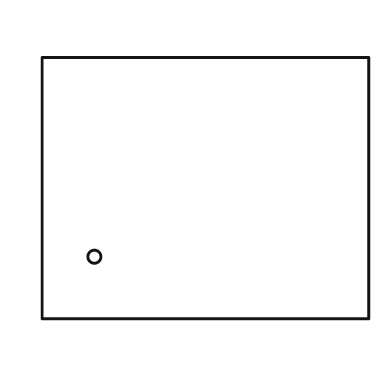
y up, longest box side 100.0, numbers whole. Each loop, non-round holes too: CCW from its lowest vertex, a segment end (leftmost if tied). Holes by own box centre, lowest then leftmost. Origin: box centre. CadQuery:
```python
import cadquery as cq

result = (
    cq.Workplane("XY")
    .moveTo(-50.0, -40.0)
    .lineTo(50.0, -40.0)
    .lineTo(50.0, 40.0)
    .lineTo(-50.0, 40.0)
    .close()
    .moveTo(-34.0, -21.0)
    .circle(2.0)
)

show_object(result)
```